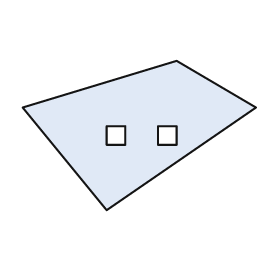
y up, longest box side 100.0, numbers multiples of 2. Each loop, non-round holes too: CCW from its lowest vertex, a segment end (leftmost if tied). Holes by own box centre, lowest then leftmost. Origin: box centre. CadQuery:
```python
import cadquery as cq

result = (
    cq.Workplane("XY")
    .moveTo(-14.0, -32.0)
    .lineTo(50.0, 12.0)
    .lineTo(16.0, 32.0)
    .lineTo(-50.0, 12.0)
    .close()
    .moveTo(-14.0, -4.0)
    .lineTo(-6.0, -4.0)
    .lineTo(-6.0, 4.0)
    .lineTo(-14.0, 4.0)
    .close()
    .moveTo(8.0, -4.0)
    .lineTo(16.0, -4.0)
    .lineTo(16.0, 4.0)
    .lineTo(8.0, 4.0)
    .close()
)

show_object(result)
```